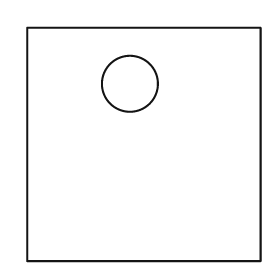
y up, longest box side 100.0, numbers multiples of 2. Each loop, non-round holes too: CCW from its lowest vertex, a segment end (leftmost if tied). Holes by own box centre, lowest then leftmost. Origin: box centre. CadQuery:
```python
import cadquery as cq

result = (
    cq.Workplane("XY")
    .moveTo(-50.0, -50.0)
    .lineTo(50.0, -50.0)
    .lineTo(50.0, 50.0)
    .lineTo(-50.0, 50.0)
    .close()
    .moveTo(-6.0, 26.0)
    .circle(12.0)
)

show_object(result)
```